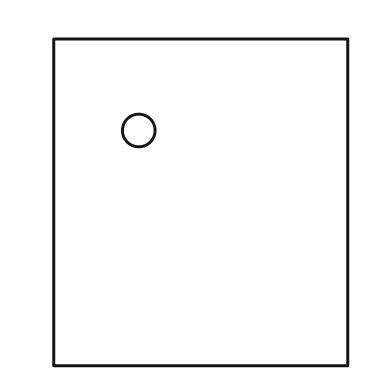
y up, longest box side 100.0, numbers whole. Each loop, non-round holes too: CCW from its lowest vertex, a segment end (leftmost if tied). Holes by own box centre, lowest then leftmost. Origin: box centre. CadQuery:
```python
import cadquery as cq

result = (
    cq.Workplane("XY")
    .moveTo(-45.0, -50.0)
    .lineTo(45.0, -50.0)
    .lineTo(45.0, 50.0)
    .lineTo(-45.0, 50.0)
    .close()
    .moveTo(-19.0, 22.0)
    .circle(5.0)
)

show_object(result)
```